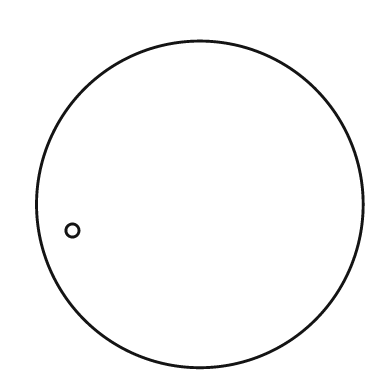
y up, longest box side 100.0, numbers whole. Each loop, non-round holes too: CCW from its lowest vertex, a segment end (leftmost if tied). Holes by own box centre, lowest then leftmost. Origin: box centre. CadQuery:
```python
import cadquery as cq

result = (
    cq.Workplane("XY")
    .moveTo(0.0, 0.0)
    .circle(50.0)
    .moveTo(-39.0, -8.0)
    .circle(2.0)
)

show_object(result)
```